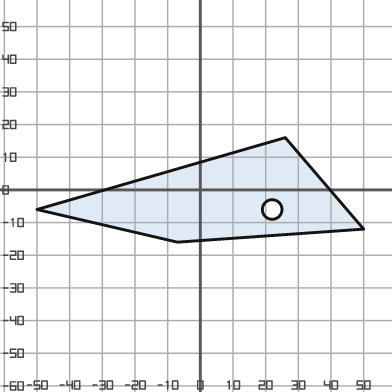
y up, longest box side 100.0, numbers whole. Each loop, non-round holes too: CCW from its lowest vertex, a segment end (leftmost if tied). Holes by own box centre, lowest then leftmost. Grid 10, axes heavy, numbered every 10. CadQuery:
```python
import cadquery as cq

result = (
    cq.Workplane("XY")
    .moveTo(-7.0, -16.0)
    .lineTo(50.0, -12.0)
    .lineTo(26.0, 16.0)
    .lineTo(-50.0, -6.0)
    .close()
    .moveTo(22.0, -6.0)
    .circle(3.0)
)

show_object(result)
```